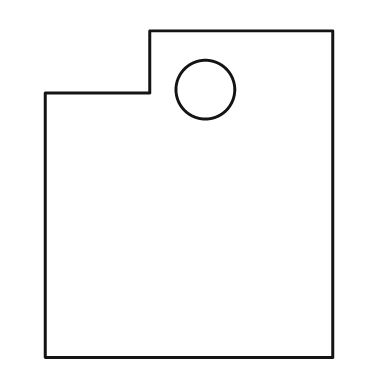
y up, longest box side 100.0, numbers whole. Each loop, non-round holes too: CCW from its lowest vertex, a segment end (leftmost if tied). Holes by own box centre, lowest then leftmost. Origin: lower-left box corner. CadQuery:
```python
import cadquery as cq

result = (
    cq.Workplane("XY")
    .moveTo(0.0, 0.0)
    .lineTo(88.0, 0.0)
    .lineTo(88.0, 100.0)
    .lineTo(32.0, 100.0)
    .lineTo(32.0, 81.0)
    .lineTo(0.0, 81.0)
    .close()
    .moveTo(49.0, 82.0)
    .circle(9.0)
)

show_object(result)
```